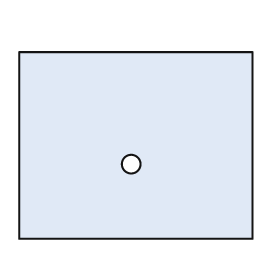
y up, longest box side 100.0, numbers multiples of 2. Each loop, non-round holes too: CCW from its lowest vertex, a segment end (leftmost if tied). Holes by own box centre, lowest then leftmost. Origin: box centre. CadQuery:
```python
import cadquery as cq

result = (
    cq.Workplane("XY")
    .moveTo(-50.0, -40.0)
    .lineTo(50.0, -40.0)
    .lineTo(50.0, 40.0)
    .lineTo(-50.0, 40.0)
    .close()
    .moveTo(-2.0, -8.0)
    .circle(4.0)
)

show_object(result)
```